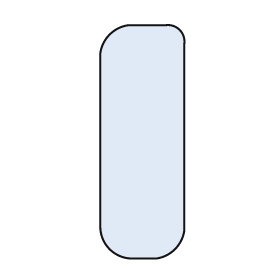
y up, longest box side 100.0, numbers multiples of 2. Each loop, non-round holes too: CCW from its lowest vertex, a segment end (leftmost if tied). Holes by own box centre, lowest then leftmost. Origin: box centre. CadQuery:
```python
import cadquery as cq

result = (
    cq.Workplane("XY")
    .moveTo(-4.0, -50.0)
    .lineTo(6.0, -50.0)
    .threePointArc((14.0, -46.0), (18.0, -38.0))
    .lineTo(18.0, 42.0)
    .threePointArc((16.0, 48.0), (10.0, 50.0))
    .lineTo(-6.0, 50.0)
    .threePointArc((-14.0, 46.0), (-18.0, 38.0))
    .lineTo(-18.0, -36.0)
    .threePointArc((-14.0, -46.0), (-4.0, -50.0))
    .close()
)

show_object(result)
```